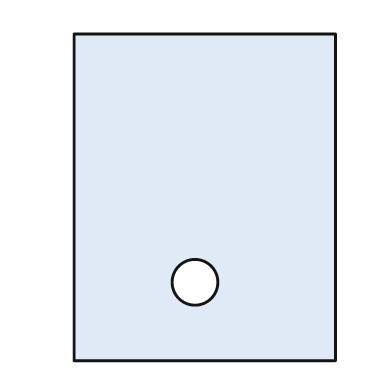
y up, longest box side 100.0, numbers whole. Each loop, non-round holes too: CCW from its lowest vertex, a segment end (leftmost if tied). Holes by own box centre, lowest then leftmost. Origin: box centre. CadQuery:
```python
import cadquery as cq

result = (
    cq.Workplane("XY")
    .moveTo(-40.0, -50.0)
    .lineTo(40.0, -50.0)
    .lineTo(40.0, 50.0)
    .lineTo(-40.0, 50.0)
    .close()
    .moveTo(-3.0, -26.0)
    .circle(7.0)
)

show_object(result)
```